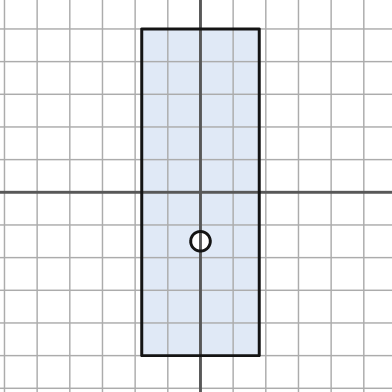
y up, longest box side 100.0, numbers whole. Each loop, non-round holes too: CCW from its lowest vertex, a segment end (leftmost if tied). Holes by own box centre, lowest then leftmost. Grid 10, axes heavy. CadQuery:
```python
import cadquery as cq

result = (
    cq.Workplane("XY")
    .moveTo(-18.0, -50.0)
    .lineTo(18.0, -50.0)
    .lineTo(18.0, 50.0)
    .lineTo(-18.0, 50.0)
    .close()
    .moveTo(0.0, -15.0)
    .circle(3.0)
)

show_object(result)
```